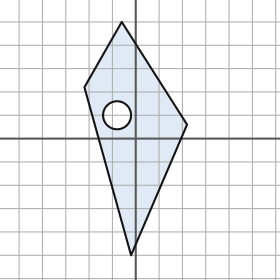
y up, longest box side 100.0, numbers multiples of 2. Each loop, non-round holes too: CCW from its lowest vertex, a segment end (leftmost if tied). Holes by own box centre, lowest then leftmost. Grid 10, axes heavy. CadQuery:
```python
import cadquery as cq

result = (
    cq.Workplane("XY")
    .moveTo(-2.0, -50.0)
    .lineTo(22.0, 6.0)
    .lineTo(-6.0, 50.0)
    .lineTo(-22.0, 22.0)
    .close()
    .moveTo(-8.0, 10.0)
    .circle(6.0)
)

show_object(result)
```